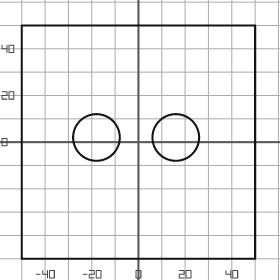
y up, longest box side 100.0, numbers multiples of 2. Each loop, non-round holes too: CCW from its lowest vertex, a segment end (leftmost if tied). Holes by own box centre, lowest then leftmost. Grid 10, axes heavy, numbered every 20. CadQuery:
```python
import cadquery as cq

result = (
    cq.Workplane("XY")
    .moveTo(-50.0, -50.0)
    .lineTo(50.0, -50.0)
    .lineTo(50.0, 50.0)
    .lineTo(-50.0, 50.0)
    .close()
    .moveTo(-18.0, 2.0)
    .circle(10.0)
    .moveTo(16.0, 2.0)
    .circle(10.0)
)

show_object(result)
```